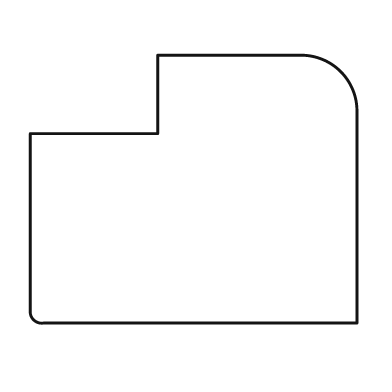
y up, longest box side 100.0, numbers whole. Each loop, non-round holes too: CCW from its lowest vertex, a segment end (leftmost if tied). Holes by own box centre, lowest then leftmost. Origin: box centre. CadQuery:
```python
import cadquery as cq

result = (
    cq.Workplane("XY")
    .moveTo(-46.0, -41.0)
    .lineTo(50.0, -41.0)
    .lineTo(50.0, 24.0)
    .threePointArc((45.0, 36.0), (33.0, 41.0))
    .lineTo(-11.0, 41.0)
    .lineTo(-11.0, 17.0)
    .lineTo(-50.0, 17.0)
    .lineTo(-50.0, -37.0)
    .threePointArc((-49.0, -40.0), (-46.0, -41.0))
    .close()
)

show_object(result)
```